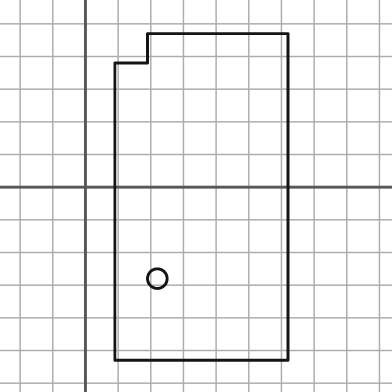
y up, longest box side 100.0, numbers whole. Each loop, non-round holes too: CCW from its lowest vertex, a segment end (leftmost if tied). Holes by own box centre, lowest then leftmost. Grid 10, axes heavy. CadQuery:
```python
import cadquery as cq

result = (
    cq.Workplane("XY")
    .moveTo(9.0, -53.0)
    .lineTo(62.0, -53.0)
    .lineTo(62.0, 47.0)
    .lineTo(19.0, 47.0)
    .lineTo(19.0, 38.0)
    .lineTo(9.0, 38.0)
    .close()
    .moveTo(22.0, -28.0)
    .circle(3.0)
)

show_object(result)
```